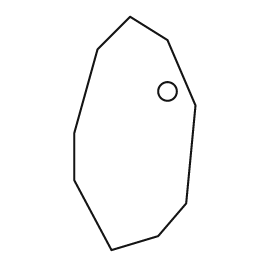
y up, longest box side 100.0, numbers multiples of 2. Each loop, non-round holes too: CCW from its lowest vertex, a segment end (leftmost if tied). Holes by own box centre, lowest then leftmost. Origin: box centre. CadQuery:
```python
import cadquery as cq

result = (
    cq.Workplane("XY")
    .moveTo(-10.0, -50.0)
    .lineTo(10.0, -44.0)
    .lineTo(22.0, -30.0)
    .lineTo(26.0, 12.0)
    .lineTo(14.0, 40.0)
    .lineTo(-2.0, 50.0)
    .lineTo(-16.0, 36.0)
    .lineTo(-26.0, 0.0)
    .lineTo(-26.0, -20.0)
    .close()
    .moveTo(14.0, 18.0)
    .circle(4.0)
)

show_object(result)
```